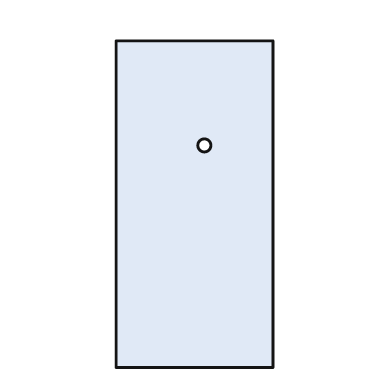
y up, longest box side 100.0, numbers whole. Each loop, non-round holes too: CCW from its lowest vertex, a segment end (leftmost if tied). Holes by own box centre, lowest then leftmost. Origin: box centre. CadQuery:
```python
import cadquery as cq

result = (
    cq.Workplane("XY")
    .moveTo(-24.0, -50.0)
    .lineTo(24.0, -50.0)
    .lineTo(24.0, 50.0)
    .lineTo(-24.0, 50.0)
    .close()
    .moveTo(3.0, 18.0)
    .circle(2.0)
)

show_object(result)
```